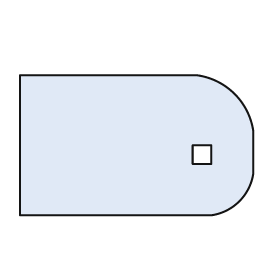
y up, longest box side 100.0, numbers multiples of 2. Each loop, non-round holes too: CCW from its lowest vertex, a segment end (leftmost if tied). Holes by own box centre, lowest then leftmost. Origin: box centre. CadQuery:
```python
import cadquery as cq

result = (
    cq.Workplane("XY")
    .moveTo(-50.0, -30.0)
    .lineTo(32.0, -30.0)
    .threePointArc((44.0, -24.0), (50.0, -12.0))
    .lineTo(50.0, 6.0)
    .threePointArc((42.0, 22.0), (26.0, 30.0))
    .lineTo(-50.0, 30.0)
    .close()
    .moveTo(24.0, -8.0)
    .lineTo(32.0, -8.0)
    .lineTo(32.0, 0.0)
    .lineTo(24.0, 0.0)
    .close()
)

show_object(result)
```